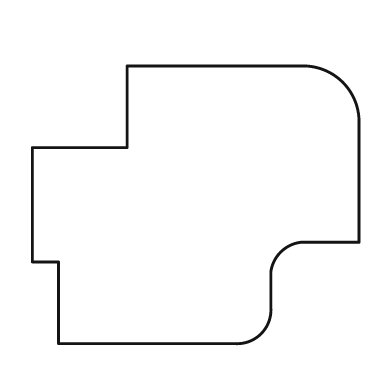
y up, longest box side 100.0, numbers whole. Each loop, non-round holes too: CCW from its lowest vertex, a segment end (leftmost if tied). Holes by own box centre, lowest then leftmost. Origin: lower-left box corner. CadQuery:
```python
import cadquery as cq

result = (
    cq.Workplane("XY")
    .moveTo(8.0, 0.0)
    .lineTo(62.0, 0.0)
    .threePointArc((70.0, 3.0), (73.0, 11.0))
    .lineTo(73.0, 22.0)
    .threePointArc((76.0, 28.0), (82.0, 31.0))
    .lineTo(100.0, 31.0)
    .lineTo(100.0, 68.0)
    .threePointArc((95.0, 80.0), (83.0, 85.0))
    .lineTo(29.0, 85.0)
    .lineTo(29.0, 60.0)
    .lineTo(0.0, 60.0)
    .lineTo(0.0, 25.0)
    .lineTo(8.0, 25.0)
    .close()
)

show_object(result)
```